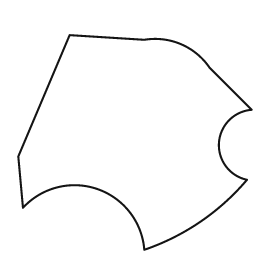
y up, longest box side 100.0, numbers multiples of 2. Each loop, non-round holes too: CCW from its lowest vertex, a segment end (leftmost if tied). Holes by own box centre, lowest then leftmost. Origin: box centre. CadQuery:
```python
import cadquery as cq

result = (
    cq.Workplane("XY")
    .moveTo(4.0, -46.0)
    .threePointArc((28.0, -34.0), (48.0, -16.0))
    .threePointArc((36.0, 0.0), (50.0, 14.0))
    .lineTo(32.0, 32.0)
    .threePointArc((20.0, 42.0), (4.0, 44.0))
    .lineTo(-28.0, 46.0)
    .lineTo(-50.0, -6.0)
    .lineTo(-48.0, -28.0)
    .threePointArc((-16.0, -20.0), (4.0, -46.0))
    .close()
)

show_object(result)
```